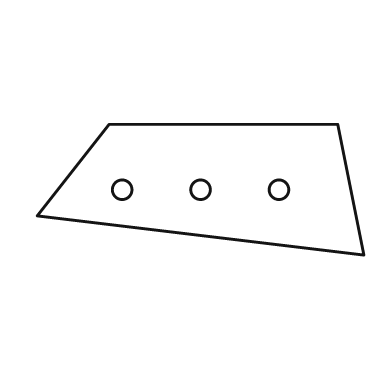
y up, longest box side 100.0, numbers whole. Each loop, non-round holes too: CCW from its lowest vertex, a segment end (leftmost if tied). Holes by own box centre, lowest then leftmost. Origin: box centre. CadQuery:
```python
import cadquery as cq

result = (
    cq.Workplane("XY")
    .moveTo(50.0, -20.0)
    .lineTo(42.0, 20.0)
    .lineTo(-28.0, 20.0)
    .lineTo(-50.0, -8.0)
    .close()
    .moveTo(-24.0, 0.0)
    .circle(3.0)
    .moveTo(0.0, 0.0)
    .circle(3.0)
    .moveTo(24.0, 0.0)
    .circle(3.0)
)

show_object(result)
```